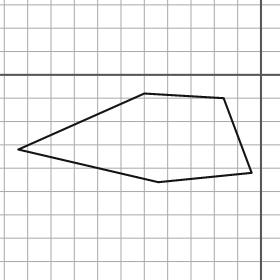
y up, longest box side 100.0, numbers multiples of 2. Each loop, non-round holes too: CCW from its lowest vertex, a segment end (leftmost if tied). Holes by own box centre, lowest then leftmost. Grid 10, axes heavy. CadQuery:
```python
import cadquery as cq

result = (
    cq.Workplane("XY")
    .moveTo(-44.0, -46.0)
    .lineTo(-4.0, -42.0)
    .lineTo(-16.0, -10.0)
    .lineTo(-50.0, -8.0)
    .lineTo(-104.0, -32.0)
    .close()
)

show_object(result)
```